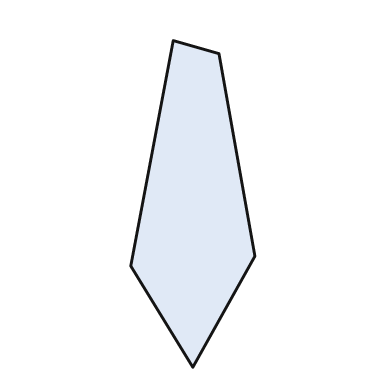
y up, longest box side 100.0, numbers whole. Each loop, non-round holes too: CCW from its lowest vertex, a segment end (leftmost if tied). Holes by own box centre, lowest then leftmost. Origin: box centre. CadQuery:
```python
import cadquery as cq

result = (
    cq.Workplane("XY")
    .moveTo(0.0, -50.0)
    .lineTo(19.0, -16.0)
    .lineTo(8.0, 46.0)
    .lineTo(-6.0, 50.0)
    .lineTo(-19.0, -19.0)
    .close()
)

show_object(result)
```